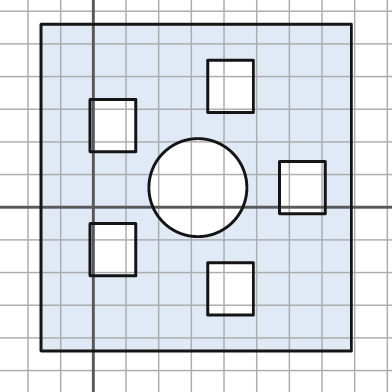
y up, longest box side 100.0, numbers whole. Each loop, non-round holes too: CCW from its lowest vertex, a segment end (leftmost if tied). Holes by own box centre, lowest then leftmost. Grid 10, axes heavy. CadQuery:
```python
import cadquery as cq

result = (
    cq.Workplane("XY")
    .moveTo(-16.0, -44.0)
    .lineTo(79.0, -44.0)
    .lineTo(79.0, 56.0)
    .lineTo(-16.0, 56.0)
    .close()
    .moveTo(35.0, -33.0)
    .lineTo(49.0, -33.0)
    .lineTo(49.0, -17.0)
    .lineTo(35.0, -17.0)
    .close()
    .moveTo(-1.0, -21.0)
    .lineTo(13.0, -21.0)
    .lineTo(13.0, -5.0)
    .lineTo(-1.0, -5.0)
    .close()
    .moveTo(32.0, 6.0)
    .circle(15.0)
    .moveTo(57.0, -2.0)
    .lineTo(71.0, -2.0)
    .lineTo(71.0, 14.0)
    .lineTo(57.0, 14.0)
    .close()
    .moveTo(-1.0, 17.0)
    .lineTo(13.0, 17.0)
    .lineTo(13.0, 33.0)
    .lineTo(-1.0, 33.0)
    .close()
    .moveTo(35.0, 29.0)
    .lineTo(49.0, 29.0)
    .lineTo(49.0, 45.0)
    .lineTo(35.0, 45.0)
    .close()
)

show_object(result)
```